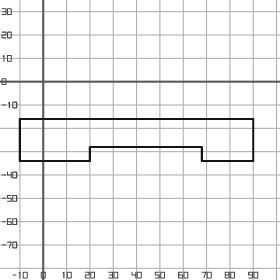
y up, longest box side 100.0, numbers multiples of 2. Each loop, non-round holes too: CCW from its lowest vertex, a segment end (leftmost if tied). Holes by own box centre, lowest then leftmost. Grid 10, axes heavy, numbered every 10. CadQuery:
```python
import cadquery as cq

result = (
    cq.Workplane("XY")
    .moveTo(-10.0, -34.0)
    .lineTo(20.0, -34.0)
    .lineTo(20.0, -28.0)
    .lineTo(68.0, -28.0)
    .lineTo(68.0, -34.0)
    .lineTo(90.0, -34.0)
    .lineTo(90.0, -16.0)
    .lineTo(-10.0, -16.0)
    .close()
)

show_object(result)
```